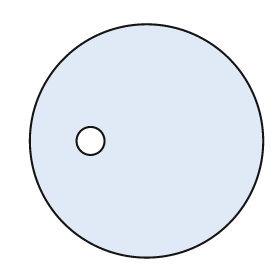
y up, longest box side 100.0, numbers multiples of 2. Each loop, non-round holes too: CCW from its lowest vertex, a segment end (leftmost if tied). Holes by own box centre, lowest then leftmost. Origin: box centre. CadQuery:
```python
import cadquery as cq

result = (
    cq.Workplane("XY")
    .moveTo(0.0, 0.0)
    .circle(50.0)
    .moveTo(-24.0, 0.0)
    .circle(6.0)
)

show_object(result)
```